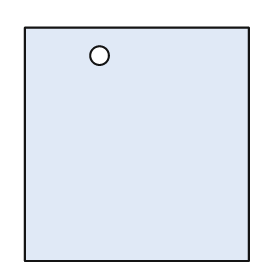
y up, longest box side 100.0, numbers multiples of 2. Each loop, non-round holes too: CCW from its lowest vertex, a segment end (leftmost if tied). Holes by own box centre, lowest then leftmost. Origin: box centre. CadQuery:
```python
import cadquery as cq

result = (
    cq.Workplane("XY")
    .moveTo(-48.0, -50.0)
    .lineTo(48.0, -50.0)
    .lineTo(48.0, 50.0)
    .lineTo(-48.0, 50.0)
    .close()
    .moveTo(-16.0, 38.0)
    .circle(4.0)
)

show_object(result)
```